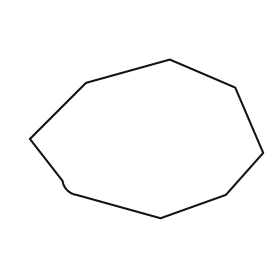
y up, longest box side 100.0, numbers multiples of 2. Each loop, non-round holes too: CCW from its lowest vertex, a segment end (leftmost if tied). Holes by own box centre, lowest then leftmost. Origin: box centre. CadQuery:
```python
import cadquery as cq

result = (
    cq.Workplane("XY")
    .moveTo(6.0, -34.0)
    .lineTo(34.0, -24.0)
    .lineTo(50.0, -6.0)
    .lineTo(38.0, 22.0)
    .lineTo(10.0, 34.0)
    .lineTo(-26.0, 24.0)
    .lineTo(-50.0, 0.0)
    .lineTo(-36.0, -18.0)
    .threePointArc((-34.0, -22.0), (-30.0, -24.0))
    .close()
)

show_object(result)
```